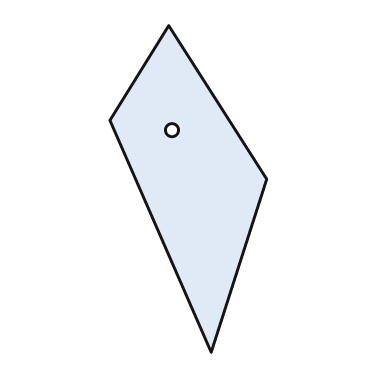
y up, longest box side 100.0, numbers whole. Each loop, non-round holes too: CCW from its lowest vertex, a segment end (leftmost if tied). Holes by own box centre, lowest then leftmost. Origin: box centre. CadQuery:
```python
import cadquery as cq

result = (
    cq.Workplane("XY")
    .moveTo(7.0, -50.0)
    .lineTo(24.0, 3.0)
    .lineTo(-6.0, 50.0)
    .lineTo(-24.0, 21.0)
    .close()
    .moveTo(-5.0, 18.0)
    .circle(2.0)
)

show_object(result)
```